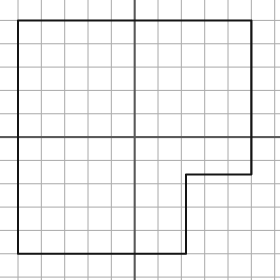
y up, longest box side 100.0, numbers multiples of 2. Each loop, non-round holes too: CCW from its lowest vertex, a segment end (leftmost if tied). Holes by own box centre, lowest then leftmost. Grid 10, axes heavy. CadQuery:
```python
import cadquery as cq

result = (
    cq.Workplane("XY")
    .moveTo(-50.0, -50.0)
    .lineTo(22.0, -50.0)
    .lineTo(22.0, -16.0)
    .lineTo(50.0, -16.0)
    .lineTo(50.0, 50.0)
    .lineTo(-50.0, 50.0)
    .close()
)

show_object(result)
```